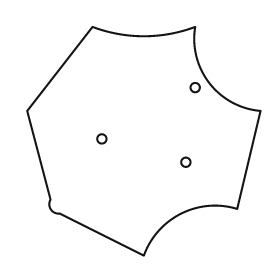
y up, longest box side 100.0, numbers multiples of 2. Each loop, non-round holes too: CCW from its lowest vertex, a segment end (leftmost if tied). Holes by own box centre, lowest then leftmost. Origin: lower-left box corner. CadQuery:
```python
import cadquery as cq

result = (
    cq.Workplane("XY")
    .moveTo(50.0, 0.0)
    .threePointArc((66.0, 18.0), (90.0, 20.0))
    .lineTo(100.0, 62.0)
    .threePointArc((78.0, 74.0), (72.0, 98.0))
    .threePointArc((50.0, 94.0), (28.0, 98.0))
    .lineTo(0.0, 62.0)
    .lineTo(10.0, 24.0)
    .threePointArc((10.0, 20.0), (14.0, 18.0))
    .close()
    .moveTo(68.0, 40.0)
    .circle(2.0)
    .moveTo(32.0, 50.0)
    .circle(2.0)
    .moveTo(72.0, 72.0)
    .circle(2.0)
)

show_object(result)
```